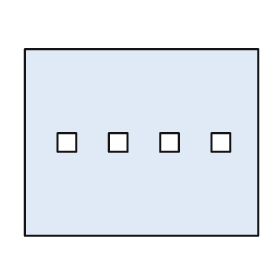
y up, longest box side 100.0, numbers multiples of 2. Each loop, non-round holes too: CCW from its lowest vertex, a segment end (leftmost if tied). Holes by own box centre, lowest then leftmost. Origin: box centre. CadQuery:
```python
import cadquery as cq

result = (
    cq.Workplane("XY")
    .moveTo(-50.0, -40.0)
    .lineTo(50.0, -40.0)
    .lineTo(50.0, 40.0)
    .lineTo(-50.0, 40.0)
    .close()
    .moveTo(-36.0, -4.0)
    .lineTo(-28.0, -4.0)
    .lineTo(-28.0, 4.0)
    .lineTo(-36.0, 4.0)
    .close()
    .moveTo(-14.0, -4.0)
    .lineTo(-6.0, -4.0)
    .lineTo(-6.0, 4.0)
    .lineTo(-14.0, 4.0)
    .close()
    .moveTo(8.0, -4.0)
    .lineTo(16.0, -4.0)
    .lineTo(16.0, 4.0)
    .lineTo(8.0, 4.0)
    .close()
    .moveTo(30.0, -4.0)
    .lineTo(38.0, -4.0)
    .lineTo(38.0, 4.0)
    .lineTo(30.0, 4.0)
    .close()
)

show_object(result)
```